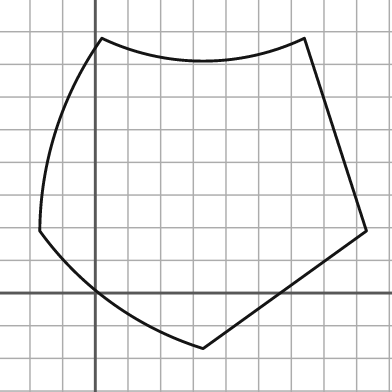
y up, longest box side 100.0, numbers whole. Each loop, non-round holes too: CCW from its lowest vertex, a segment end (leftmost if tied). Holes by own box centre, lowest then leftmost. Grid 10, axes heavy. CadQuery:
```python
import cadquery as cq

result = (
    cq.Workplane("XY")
    .moveTo(33.0, -17.0)
    .lineTo(83.0, 19.0)
    .lineTo(64.0, 78.0)
    .threePointArc((33.0, 71.0), (2.0, 78.0))
    .threePointArc((-12.0, 50.0), (-17.0, 19.0))
    .threePointArc((5.0, -3.0), (33.0, -17.0))
    .close()
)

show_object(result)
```